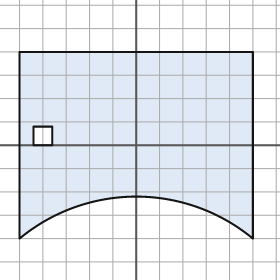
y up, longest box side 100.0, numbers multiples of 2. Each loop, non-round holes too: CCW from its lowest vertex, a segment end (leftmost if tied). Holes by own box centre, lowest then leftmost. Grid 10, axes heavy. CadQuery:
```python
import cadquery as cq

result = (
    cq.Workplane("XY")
    .moveTo(-50.0, -40.0)
    .threePointArc((0.0, -22.0), (50.0, -40.0))
    .lineTo(50.0, 40.0)
    .lineTo(-50.0, 40.0)
    .close()
    .moveTo(-44.0, 0.0)
    .lineTo(-36.0, 0.0)
    .lineTo(-36.0, 8.0)
    .lineTo(-44.0, 8.0)
    .close()
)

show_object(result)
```